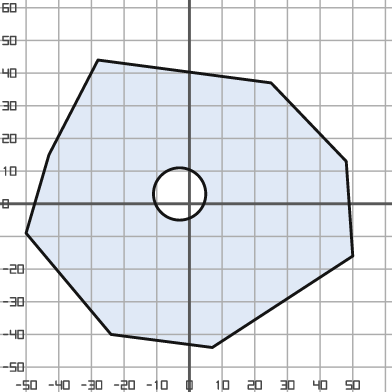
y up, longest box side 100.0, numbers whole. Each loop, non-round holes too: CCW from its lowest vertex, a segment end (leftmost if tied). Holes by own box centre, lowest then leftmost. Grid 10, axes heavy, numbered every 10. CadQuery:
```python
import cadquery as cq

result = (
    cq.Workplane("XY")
    .moveTo(7.0, -44.0)
    .lineTo(50.0, -16.0)
    .lineTo(48.0, 13.0)
    .lineTo(25.0, 37.0)
    .lineTo(-28.0, 44.0)
    .lineTo(-43.0, 15.0)
    .lineTo(-50.0, -9.0)
    .lineTo(-24.0, -40.0)
    .close()
    .moveTo(-3.0, 3.0)
    .circle(8.0)
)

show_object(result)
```